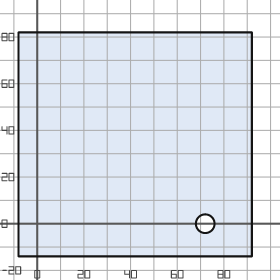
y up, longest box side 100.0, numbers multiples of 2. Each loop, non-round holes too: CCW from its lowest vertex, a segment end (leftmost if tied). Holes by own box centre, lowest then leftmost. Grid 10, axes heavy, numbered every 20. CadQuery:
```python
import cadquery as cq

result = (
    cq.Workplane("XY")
    .moveTo(-8.0, -14.0)
    .lineTo(92.0, -14.0)
    .lineTo(92.0, 82.0)
    .lineTo(-8.0, 82.0)
    .close()
    .moveTo(72.0, 0.0)
    .circle(4.0)
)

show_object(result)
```